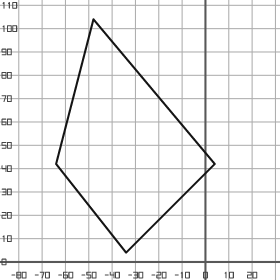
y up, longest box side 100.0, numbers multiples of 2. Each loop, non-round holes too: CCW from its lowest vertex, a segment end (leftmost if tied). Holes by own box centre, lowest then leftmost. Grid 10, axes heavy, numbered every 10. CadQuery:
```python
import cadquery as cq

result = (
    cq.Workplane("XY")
    .moveTo(-34.0, 4.0)
    .lineTo(4.0, 42.0)
    .lineTo(-48.0, 104.0)
    .lineTo(-64.0, 42.0)
    .close()
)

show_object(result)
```